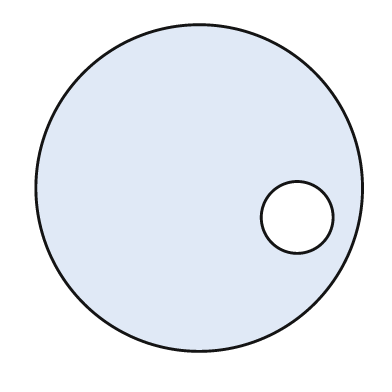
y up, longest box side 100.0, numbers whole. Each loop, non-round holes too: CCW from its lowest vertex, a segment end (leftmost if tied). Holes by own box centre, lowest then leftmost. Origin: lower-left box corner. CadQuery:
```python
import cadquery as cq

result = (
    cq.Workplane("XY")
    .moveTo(50.0, 50.0)
    .circle(50.0)
    .moveTo(80.0, 41.0)
    .circle(11.0)
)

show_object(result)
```